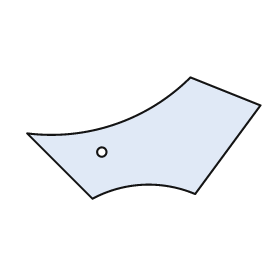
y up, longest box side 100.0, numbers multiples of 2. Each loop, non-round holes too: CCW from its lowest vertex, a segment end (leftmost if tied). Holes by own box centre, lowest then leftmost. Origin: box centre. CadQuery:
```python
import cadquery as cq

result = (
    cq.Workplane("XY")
    .moveTo(-22.0, -26.0)
    .threePointArc((0.0, -20.0), (22.0, -24.0))
    .lineTo(50.0, 14.0)
    .lineTo(20.0, 26.0)
    .threePointArc((-12.0, 6.0), (-50.0, 2.0))
    .close()
    .moveTo(-18.0, -6.0)
    .circle(2.0)
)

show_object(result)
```